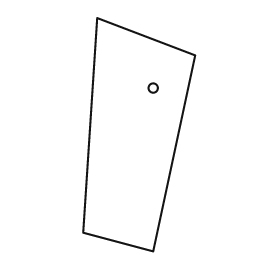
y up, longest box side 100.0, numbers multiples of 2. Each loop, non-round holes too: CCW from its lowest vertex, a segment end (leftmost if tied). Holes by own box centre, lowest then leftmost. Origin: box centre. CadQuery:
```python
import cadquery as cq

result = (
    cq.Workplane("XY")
    .moveTo(6.0, -50.0)
    .lineTo(24.0, 34.0)
    .lineTo(-18.0, 50.0)
    .lineTo(-24.0, -42.0)
    .close()
    .moveTo(6.0, 20.0)
    .circle(2.0)
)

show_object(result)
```